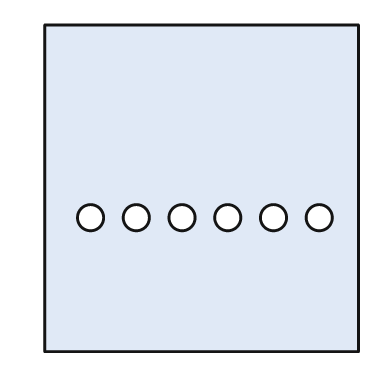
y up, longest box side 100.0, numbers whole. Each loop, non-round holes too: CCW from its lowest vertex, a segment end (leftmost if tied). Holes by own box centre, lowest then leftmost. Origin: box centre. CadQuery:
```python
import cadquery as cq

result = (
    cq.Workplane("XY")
    .moveTo(-48.0, -50.0)
    .lineTo(48.0, -50.0)
    .lineTo(48.0, 50.0)
    .lineTo(-48.0, 50.0)
    .close()
    .moveTo(-34.0, -9.0)
    .circle(4.0)
    .moveTo(-20.0, -9.0)
    .circle(4.0)
    .moveTo(-6.0, -9.0)
    .circle(4.0)
    .moveTo(8.0, -9.0)
    .circle(4.0)
    .moveTo(22.0, -9.0)
    .circle(4.0)
    .moveTo(36.0, -9.0)
    .circle(4.0)
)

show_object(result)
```